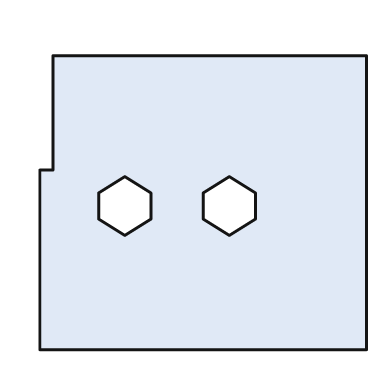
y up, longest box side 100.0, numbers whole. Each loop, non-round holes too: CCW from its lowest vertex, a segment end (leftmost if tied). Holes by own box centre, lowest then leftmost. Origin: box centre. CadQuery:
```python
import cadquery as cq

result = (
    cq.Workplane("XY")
    .moveTo(-50.0, -45.0)
    .lineTo(50.0, -45.0)
    .lineTo(50.0, 45.0)
    .lineTo(-46.0, 45.0)
    .lineTo(-46.0, 10.0)
    .lineTo(-50.0, 10.0)
    .close()
    .moveTo(-24.0, -10.0)
    .lineTo(-16.0, -5.0)
    .lineTo(-16.0, 3.0)
    .lineTo(-24.0, 8.0)
    .lineTo(-32.0, 3.0)
    .lineTo(-32.0, -5.0)
    .close()
    .moveTo(8.0, -10.0)
    .lineTo(16.0, -5.0)
    .lineTo(16.0, 3.0)
    .lineTo(8.0, 8.0)
    .lineTo(0.0, 3.0)
    .lineTo(0.0, -5.0)
    .close()
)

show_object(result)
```